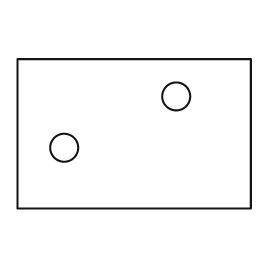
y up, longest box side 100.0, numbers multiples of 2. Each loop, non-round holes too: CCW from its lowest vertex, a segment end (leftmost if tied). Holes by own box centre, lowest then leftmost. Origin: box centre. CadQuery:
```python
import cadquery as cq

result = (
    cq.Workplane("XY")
    .moveTo(-50.0, -32.0)
    .lineTo(50.0, -32.0)
    .lineTo(50.0, 32.0)
    .lineTo(-50.0, 32.0)
    .close()
    .moveTo(-30.0, -6.0)
    .circle(6.0)
    .moveTo(18.0, 16.0)
    .circle(6.0)
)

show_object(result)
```